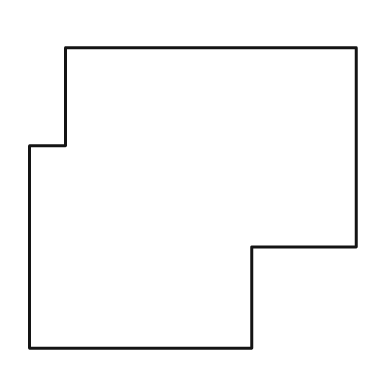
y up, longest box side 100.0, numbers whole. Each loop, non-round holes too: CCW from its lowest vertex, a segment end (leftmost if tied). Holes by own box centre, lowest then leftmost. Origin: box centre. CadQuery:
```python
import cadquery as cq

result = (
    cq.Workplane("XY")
    .moveTo(-50.0, -46.0)
    .lineTo(18.0, -46.0)
    .lineTo(18.0, -15.0)
    .lineTo(50.0, -15.0)
    .lineTo(50.0, 46.0)
    .lineTo(-39.0, 46.0)
    .lineTo(-39.0, 16.0)
    .lineTo(-50.0, 16.0)
    .close()
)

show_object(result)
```